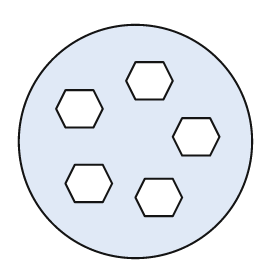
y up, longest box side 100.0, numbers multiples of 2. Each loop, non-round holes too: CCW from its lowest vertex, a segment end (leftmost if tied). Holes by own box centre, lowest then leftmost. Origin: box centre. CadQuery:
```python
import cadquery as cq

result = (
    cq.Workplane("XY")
    .moveTo(0.0, 0.0)
    .circle(50.0)
    .moveTo(4.0, -32.0)
    .lineTo(16.0, -32.0)
    .lineTo(20.0, -24.0)
    .lineTo(16.0, -16.0)
    .lineTo(4.0, -16.0)
    .lineTo(0.0, -24.0)
    .close()
    .moveTo(-26.0, -26.0)
    .lineTo(-14.0, -26.0)
    .lineTo(-10.0, -18.0)
    .lineTo(-14.0, -10.0)
    .lineTo(-26.0, -10.0)
    .lineTo(-30.0, -18.0)
    .close()
    .moveTo(20.0, -6.0)
    .lineTo(32.0, -6.0)
    .lineTo(36.0, 2.0)
    .lineTo(32.0, 10.0)
    .lineTo(20.0, 10.0)
    .lineTo(16.0, 2.0)
    .close()
    .moveTo(-30.0, 6.0)
    .lineTo(-18.0, 6.0)
    .lineTo(-14.0, 14.0)
    .lineTo(-18.0, 22.0)
    .lineTo(-30.0, 22.0)
    .lineTo(-34.0, 14.0)
    .close()
    .moveTo(0.0, 18.0)
    .lineTo(12.0, 18.0)
    .lineTo(16.0, 26.0)
    .lineTo(12.0, 34.0)
    .lineTo(0.0, 34.0)
    .lineTo(-4.0, 26.0)
    .close()
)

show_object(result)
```